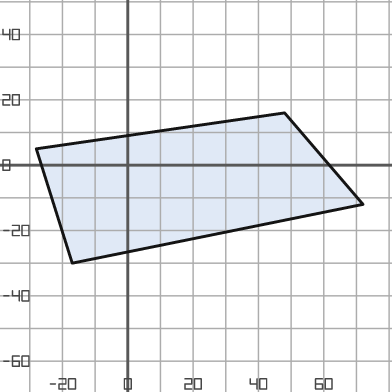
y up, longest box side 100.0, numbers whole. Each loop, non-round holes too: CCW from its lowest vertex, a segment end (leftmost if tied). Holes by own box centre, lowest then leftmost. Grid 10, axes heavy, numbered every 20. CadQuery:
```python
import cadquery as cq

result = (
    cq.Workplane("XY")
    .moveTo(-17.0, -30.0)
    .lineTo(72.0, -12.0)
    .lineTo(48.0, 16.0)
    .lineTo(-28.0, 5.0)
    .close()
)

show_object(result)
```